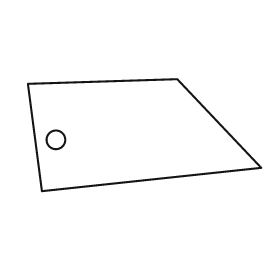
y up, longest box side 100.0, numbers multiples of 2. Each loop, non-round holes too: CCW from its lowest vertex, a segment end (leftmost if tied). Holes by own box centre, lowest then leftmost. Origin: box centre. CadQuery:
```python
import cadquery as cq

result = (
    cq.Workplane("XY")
    .moveTo(-44.0, -24.0)
    .lineTo(50.0, -14.0)
    .lineTo(14.0, 24.0)
    .lineTo(-50.0, 22.0)
    .close()
    .moveTo(-38.0, -2.0)
    .circle(4.0)
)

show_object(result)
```